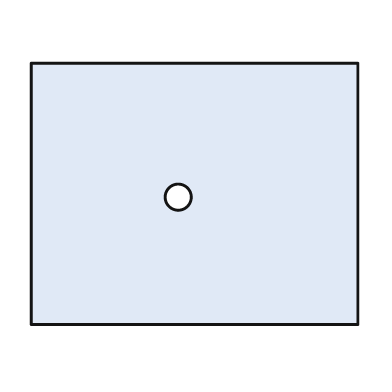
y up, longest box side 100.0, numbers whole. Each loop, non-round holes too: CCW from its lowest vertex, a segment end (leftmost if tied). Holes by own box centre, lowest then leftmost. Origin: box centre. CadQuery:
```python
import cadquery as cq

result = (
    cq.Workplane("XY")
    .moveTo(-50.0, -40.0)
    .lineTo(50.0, -40.0)
    .lineTo(50.0, 40.0)
    .lineTo(-50.0, 40.0)
    .close()
    .moveTo(-5.0, -1.0)
    .circle(4.0)
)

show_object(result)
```